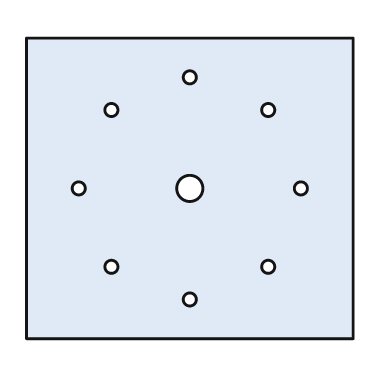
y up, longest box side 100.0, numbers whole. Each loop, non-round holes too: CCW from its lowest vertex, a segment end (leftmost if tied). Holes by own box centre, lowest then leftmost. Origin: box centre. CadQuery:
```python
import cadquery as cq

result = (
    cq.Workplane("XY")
    .moveTo(-50.0, -46.0)
    .lineTo(50.0, -46.0)
    .lineTo(50.0, 46.0)
    .lineTo(-50.0, 46.0)
    .close()
    .moveTo(0.0, -34.0)
    .circle(2.0)
    .moveTo(-24.0, -24.0)
    .circle(2.0)
    .moveTo(24.0, -24.0)
    .circle(2.0)
    .moveTo(-34.0, 0.0)
    .circle(2.0)
    .moveTo(0.0, 0.0)
    .circle(4.0)
    .moveTo(34.0, 0.0)
    .circle(2.0)
    .moveTo(-24.0, 24.0)
    .circle(2.0)
    .moveTo(24.0, 24.0)
    .circle(2.0)
    .moveTo(0.0, 34.0)
    .circle(2.0)
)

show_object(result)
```